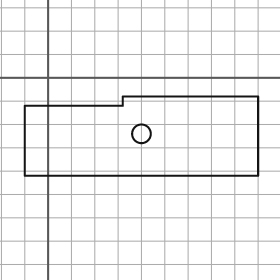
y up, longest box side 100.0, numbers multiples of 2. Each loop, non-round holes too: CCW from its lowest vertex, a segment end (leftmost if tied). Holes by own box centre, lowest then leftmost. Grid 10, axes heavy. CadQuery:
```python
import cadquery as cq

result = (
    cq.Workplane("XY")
    .moveTo(-10.0, -42.0)
    .lineTo(90.0, -42.0)
    .lineTo(90.0, -8.0)
    .lineTo(32.0, -8.0)
    .lineTo(32.0, -12.0)
    .lineTo(-10.0, -12.0)
    .close()
    .moveTo(40.0, -24.0)
    .circle(4.0)
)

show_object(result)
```